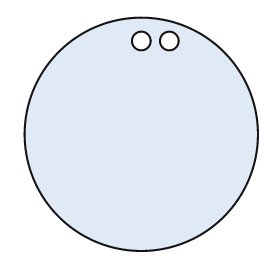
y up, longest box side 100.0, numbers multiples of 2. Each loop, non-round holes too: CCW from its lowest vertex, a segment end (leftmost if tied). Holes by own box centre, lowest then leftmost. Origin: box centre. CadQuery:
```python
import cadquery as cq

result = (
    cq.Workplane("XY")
    .moveTo(0.0, 0.0)
    .circle(50.0)
    .moveTo(0.0, 40.0)
    .circle(4.0)
    .moveTo(12.0, 40.0)
    .circle(4.0)
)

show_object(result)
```